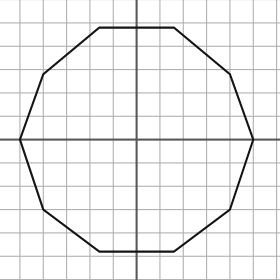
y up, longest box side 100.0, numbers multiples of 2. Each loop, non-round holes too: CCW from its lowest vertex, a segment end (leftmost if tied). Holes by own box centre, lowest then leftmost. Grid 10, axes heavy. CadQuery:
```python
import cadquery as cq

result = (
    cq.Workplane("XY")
    .moveTo(-16.0, -48.0)
    .lineTo(16.0, -48.0)
    .lineTo(40.0, -30.0)
    .lineTo(50.0, 0.0)
    .lineTo(40.0, 28.0)
    .lineTo(16.0, 48.0)
    .lineTo(-16.0, 48.0)
    .lineTo(-40.0, 28.0)
    .lineTo(-50.0, 0.0)
    .lineTo(-40.0, -30.0)
    .close()
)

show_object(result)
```